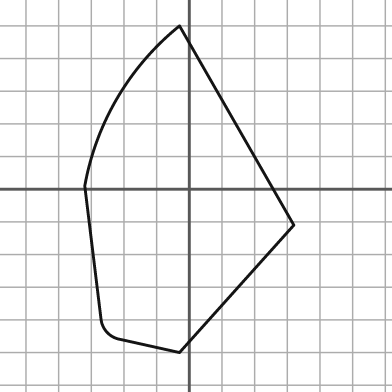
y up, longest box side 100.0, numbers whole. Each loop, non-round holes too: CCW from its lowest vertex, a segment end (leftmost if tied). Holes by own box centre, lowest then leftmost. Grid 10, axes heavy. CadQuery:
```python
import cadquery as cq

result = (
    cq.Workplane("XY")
    .moveTo(-3.0, -50.0)
    .lineTo(32.0, -11.0)
    .lineTo(-3.0, 50.0)
    .threePointArc((-22.0, 28.0), (-32.0, 1.0))
    .lineTo(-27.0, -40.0)
    .threePointArc((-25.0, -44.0), (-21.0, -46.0))
    .close()
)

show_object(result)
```